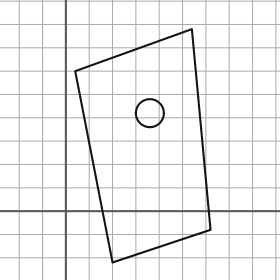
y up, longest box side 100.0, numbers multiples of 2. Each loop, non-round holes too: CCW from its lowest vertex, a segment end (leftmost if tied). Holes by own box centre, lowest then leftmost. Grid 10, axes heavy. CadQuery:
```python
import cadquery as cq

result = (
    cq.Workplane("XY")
    .moveTo(20.0, -22.0)
    .lineTo(62.0, -8.0)
    .lineTo(54.0, 78.0)
    .lineTo(4.0, 60.0)
    .close()
    .moveTo(36.0, 42.0)
    .circle(6.0)
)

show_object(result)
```